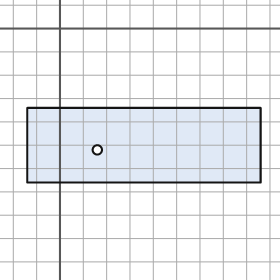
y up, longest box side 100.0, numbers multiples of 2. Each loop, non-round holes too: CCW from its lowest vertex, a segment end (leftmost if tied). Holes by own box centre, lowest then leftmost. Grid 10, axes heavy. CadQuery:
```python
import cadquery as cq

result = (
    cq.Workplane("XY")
    .moveTo(-14.0, -66.0)
    .lineTo(86.0, -66.0)
    .lineTo(86.0, -34.0)
    .lineTo(-14.0, -34.0)
    .close()
    .moveTo(16.0, -52.0)
    .circle(2.0)
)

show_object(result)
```